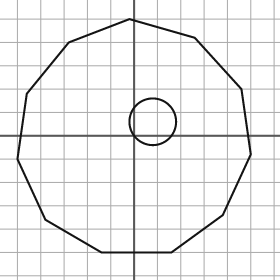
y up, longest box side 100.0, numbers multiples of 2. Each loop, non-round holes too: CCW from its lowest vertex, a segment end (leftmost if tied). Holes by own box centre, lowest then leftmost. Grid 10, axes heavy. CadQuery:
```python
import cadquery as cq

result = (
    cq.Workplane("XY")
    .moveTo(-14.0, -50.0)
    .lineTo(16.0, -50.0)
    .lineTo(38.0, -34.0)
    .lineTo(50.0, -8.0)
    .lineTo(46.0, 20.0)
    .lineTo(26.0, 42.0)
    .lineTo(-2.0, 50.0)
    .lineTo(-28.0, 40.0)
    .lineTo(-46.0, 18.0)
    .lineTo(-50.0, -10.0)
    .lineTo(-38.0, -36.0)
    .close()
    .moveTo(8.0, 6.0)
    .circle(10.0)
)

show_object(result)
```